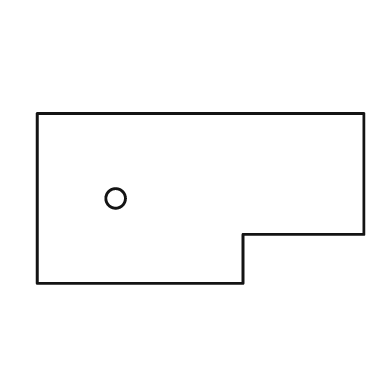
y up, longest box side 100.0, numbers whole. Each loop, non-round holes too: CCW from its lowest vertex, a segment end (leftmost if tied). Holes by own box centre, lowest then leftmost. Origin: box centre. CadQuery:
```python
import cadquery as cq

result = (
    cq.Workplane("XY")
    .moveTo(-50.0, -26.0)
    .lineTo(13.0, -26.0)
    .lineTo(13.0, -11.0)
    .lineTo(50.0, -11.0)
    .lineTo(50.0, 26.0)
    .lineTo(-50.0, 26.0)
    .close()
    .moveTo(-26.0, 0.0)
    .circle(3.0)
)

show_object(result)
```